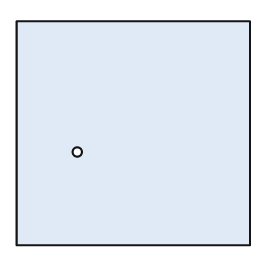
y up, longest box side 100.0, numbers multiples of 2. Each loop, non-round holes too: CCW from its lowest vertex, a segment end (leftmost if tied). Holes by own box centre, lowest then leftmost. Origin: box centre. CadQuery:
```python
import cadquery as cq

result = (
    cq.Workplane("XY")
    .moveTo(-50.0, -48.0)
    .lineTo(50.0, -48.0)
    .lineTo(50.0, 48.0)
    .lineTo(-50.0, 48.0)
    .close()
    .moveTo(-24.0, -8.0)
    .circle(2.0)
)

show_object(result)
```